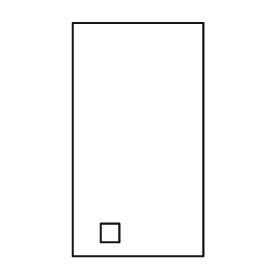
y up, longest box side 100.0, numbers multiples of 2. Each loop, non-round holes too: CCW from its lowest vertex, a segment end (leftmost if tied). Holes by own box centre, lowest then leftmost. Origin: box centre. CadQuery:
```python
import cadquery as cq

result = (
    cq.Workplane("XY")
    .moveTo(-28.0, -50.0)
    .lineTo(28.0, -50.0)
    .lineTo(28.0, 50.0)
    .lineTo(-28.0, 50.0)
    .close()
    .moveTo(-16.0, -44.0)
    .lineTo(-8.0, -44.0)
    .lineTo(-8.0, -36.0)
    .lineTo(-16.0, -36.0)
    .close()
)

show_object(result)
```